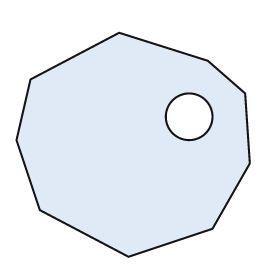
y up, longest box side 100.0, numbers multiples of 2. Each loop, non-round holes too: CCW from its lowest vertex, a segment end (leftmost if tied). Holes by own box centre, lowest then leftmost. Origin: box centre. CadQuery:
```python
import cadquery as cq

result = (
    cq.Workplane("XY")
    .moveTo(-2.0, -48.0)
    .lineTo(34.0, -36.0)
    .lineTo(50.0, -8.0)
    .lineTo(48.0, 22.0)
    .lineTo(32.0, 36.0)
    .lineTo(-6.0, 48.0)
    .lineTo(-44.0, 28.0)
    .lineTo(-50.0, 2.0)
    .lineTo(-40.0, -28.0)
    .close()
    .moveTo(24.0, 12.0)
    .circle(10.0)
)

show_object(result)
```